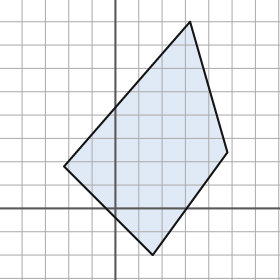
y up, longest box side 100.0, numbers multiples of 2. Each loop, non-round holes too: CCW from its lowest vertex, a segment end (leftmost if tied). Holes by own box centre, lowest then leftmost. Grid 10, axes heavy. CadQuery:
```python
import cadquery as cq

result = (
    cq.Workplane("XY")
    .moveTo(16.0, -20.0)
    .lineTo(48.0, 24.0)
    .lineTo(32.0, 80.0)
    .lineTo(-22.0, 18.0)
    .close()
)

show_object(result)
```